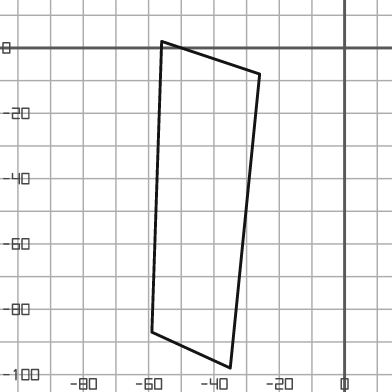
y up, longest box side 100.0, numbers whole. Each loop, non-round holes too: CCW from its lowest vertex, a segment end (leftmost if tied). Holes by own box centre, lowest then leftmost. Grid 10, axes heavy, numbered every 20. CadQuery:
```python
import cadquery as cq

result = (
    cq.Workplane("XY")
    .moveTo(-35.0, -98.0)
    .lineTo(-26.0, -8.0)
    .lineTo(-56.0, 2.0)
    .lineTo(-59.0, -87.0)
    .close()
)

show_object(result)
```